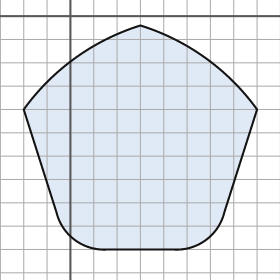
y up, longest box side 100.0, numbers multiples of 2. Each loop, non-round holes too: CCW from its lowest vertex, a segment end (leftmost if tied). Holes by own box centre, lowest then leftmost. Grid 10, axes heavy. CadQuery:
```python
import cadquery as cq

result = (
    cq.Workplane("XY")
    .moveTo(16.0, -100.0)
    .lineTo(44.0, -100.0)
    .threePointArc((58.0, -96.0), (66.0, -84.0))
    .lineTo(80.0, -40.0)
    .threePointArc((58.0, -18.0), (30.0, -4.0))
    .threePointArc((2.0, -18.0), (-20.0, -40.0))
    .lineTo(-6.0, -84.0)
    .threePointArc((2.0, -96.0), (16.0, -100.0))
    .close()
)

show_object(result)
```